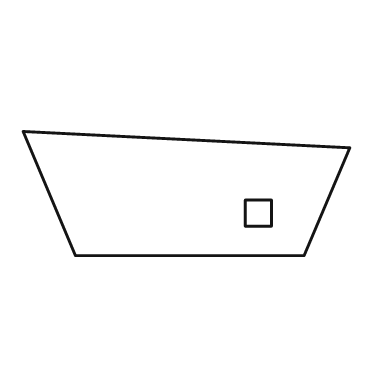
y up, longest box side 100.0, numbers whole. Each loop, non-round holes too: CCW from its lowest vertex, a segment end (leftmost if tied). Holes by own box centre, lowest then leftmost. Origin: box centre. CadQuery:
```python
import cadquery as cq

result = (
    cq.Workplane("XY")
    .moveTo(-34.0, -19.0)
    .lineTo(36.0, -19.0)
    .lineTo(50.0, 14.0)
    .lineTo(-50.0, 19.0)
    .close()
    .moveTo(18.0, -10.0)
    .lineTo(26.0, -10.0)
    .lineTo(26.0, -2.0)
    .lineTo(18.0, -2.0)
    .close()
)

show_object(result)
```